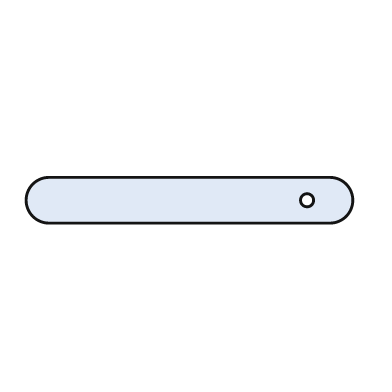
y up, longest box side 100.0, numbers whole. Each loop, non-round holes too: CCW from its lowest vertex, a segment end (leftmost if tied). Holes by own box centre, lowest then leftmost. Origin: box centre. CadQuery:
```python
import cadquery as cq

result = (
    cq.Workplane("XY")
    .moveTo(-43.0, -7.0)
    .lineTo(43.0, -7.0)
    .threePointArc((50.0, 0.0), (43.0, 7.0))
    .lineTo(-43.0, 7.0)
    .threePointArc((-50.0, 0.0), (-43.0, -7.0))
    .close()
    .moveTo(36.0, 0.0)
    .circle(2.0)
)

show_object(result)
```